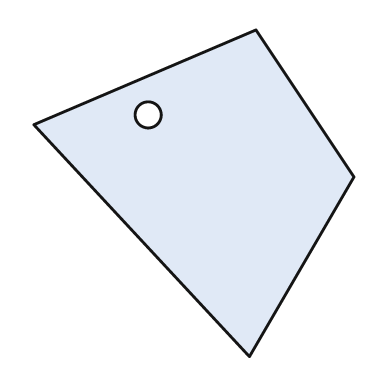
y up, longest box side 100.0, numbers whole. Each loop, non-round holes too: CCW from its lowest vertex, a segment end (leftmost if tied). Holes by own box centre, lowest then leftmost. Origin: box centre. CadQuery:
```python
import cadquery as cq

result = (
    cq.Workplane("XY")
    .moveTo(17.0, -50.0)
    .lineTo(49.0, 5.0)
    .lineTo(19.0, 50.0)
    .lineTo(-49.0, 21.0)
    .close()
    .moveTo(-14.0, 24.0)
    .circle(4.0)
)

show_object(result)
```